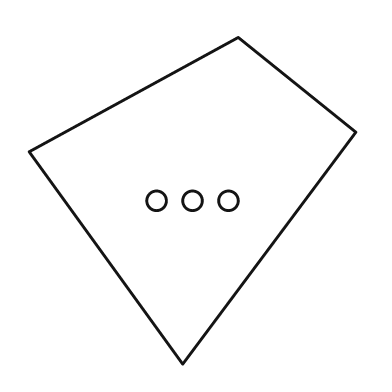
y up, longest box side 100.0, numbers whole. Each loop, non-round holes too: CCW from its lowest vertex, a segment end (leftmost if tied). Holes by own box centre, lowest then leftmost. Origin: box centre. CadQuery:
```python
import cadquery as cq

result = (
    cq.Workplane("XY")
    .moveTo(-3.0, -50.0)
    .lineTo(50.0, 21.0)
    .lineTo(14.0, 50.0)
    .lineTo(-50.0, 15.0)
    .close()
    .moveTo(-11.0, 0.0)
    .circle(3.0)
    .moveTo(0.0, 0.0)
    .circle(3.0)
    .moveTo(11.0, 0.0)
    .circle(3.0)
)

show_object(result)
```